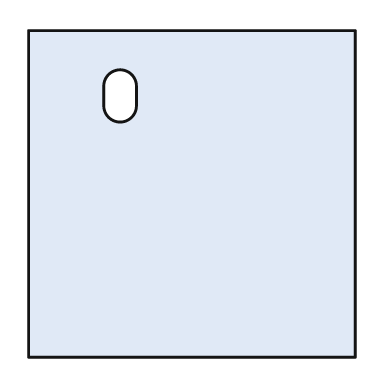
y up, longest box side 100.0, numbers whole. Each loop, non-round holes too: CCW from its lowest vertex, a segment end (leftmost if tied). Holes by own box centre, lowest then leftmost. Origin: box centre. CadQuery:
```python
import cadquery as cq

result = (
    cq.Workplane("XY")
    .moveTo(-50.0, -50.0)
    .lineTo(50.0, -50.0)
    .lineTo(50.0, 50.0)
    .lineTo(-50.0, 50.0)
    .close()
    .moveTo(-27.0, 27.0)
    .threePointArc((-22.0, 22.0), (-17.0, 27.0))
    .lineTo(-17.0, 33.0)
    .threePointArc((-22.0, 38.0), (-27.0, 33.0))
    .close()
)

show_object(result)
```